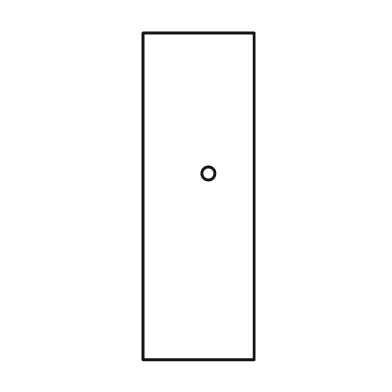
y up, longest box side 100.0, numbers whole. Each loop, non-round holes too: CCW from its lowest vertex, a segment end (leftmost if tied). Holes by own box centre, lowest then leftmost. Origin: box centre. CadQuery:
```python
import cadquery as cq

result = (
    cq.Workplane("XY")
    .moveTo(-17.0, -50.0)
    .lineTo(17.0, -50.0)
    .lineTo(17.0, 50.0)
    .lineTo(-17.0, 50.0)
    .close()
    .moveTo(3.0, 7.0)
    .circle(2.0)
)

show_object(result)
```